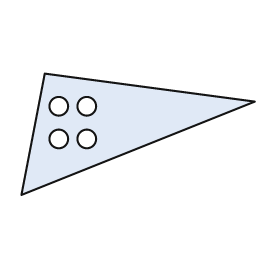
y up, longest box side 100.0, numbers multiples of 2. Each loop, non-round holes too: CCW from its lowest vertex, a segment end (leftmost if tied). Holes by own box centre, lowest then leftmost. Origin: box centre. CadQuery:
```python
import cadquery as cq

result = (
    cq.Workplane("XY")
    .moveTo(-50.0, -26.0)
    .lineTo(50.0, 14.0)
    .lineTo(-40.0, 26.0)
    .close()
    .moveTo(-34.0, -2.0)
    .circle(4.0)
    .moveTo(-22.0, -2.0)
    .circle(4.0)
    .moveTo(-34.0, 12.0)
    .circle(4.0)
    .moveTo(-22.0, 12.0)
    .circle(4.0)
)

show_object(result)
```